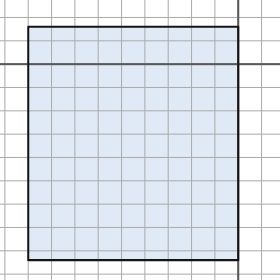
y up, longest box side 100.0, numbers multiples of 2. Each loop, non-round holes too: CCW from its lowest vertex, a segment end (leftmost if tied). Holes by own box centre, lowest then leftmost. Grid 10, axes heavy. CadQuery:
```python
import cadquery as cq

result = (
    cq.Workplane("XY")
    .moveTo(-90.0, -84.0)
    .lineTo(0.0, -84.0)
    .lineTo(0.0, 16.0)
    .lineTo(-90.0, 16.0)
    .close()
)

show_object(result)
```